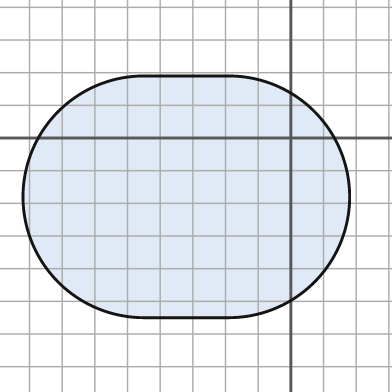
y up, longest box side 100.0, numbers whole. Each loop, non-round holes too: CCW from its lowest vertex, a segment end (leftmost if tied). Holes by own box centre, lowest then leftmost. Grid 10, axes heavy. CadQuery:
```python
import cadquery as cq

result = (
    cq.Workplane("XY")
    .moveTo(-45.0, -55.0)
    .lineTo(-19.0, -55.0)
    .threePointArc((18.0, -18.0), (-19.0, 19.0))
    .lineTo(-45.0, 19.0)
    .threePointArc((-82.0, -18.0), (-45.0, -55.0))
    .close()
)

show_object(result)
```